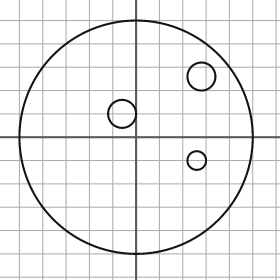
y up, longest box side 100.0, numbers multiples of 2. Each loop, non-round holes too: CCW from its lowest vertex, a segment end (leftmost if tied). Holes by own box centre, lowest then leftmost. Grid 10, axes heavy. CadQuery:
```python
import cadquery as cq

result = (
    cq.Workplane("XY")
    .moveTo(0.0, 0.0)
    .circle(50.0)
    .moveTo(26.0, -10.0)
    .circle(4.0)
    .moveTo(-6.0, 10.0)
    .circle(6.0)
    .moveTo(28.0, 26.0)
    .circle(6.0)
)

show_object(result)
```